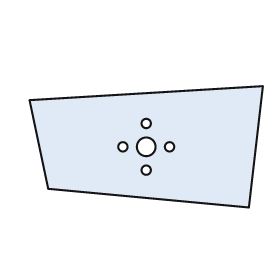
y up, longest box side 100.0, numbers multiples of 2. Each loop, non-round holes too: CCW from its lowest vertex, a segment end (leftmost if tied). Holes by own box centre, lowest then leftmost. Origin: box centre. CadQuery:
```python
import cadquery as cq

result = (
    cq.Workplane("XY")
    .moveTo(44.0, -26.0)
    .lineTo(50.0, 26.0)
    .lineTo(-50.0, 20.0)
    .lineTo(-42.0, -18.0)
    .close()
    .moveTo(0.0, -10.0)
    .circle(2.0)
    .moveTo(-10.0, 0.0)
    .circle(2.0)
    .moveTo(0.0, 0.0)
    .circle(4.0)
    .moveTo(10.0, 0.0)
    .circle(2.0)
    .moveTo(0.0, 10.0)
    .circle(2.0)
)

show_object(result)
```